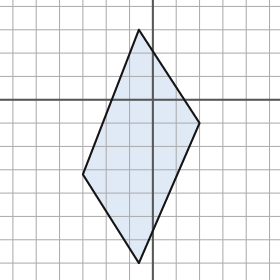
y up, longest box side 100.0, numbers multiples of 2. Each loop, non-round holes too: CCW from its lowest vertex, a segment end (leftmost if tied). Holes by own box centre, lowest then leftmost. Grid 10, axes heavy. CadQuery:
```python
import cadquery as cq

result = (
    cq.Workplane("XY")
    .moveTo(-6.0, -70.0)
    .lineTo(20.0, -10.0)
    .lineTo(-6.0, 30.0)
    .lineTo(-30.0, -32.0)
    .close()
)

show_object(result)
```